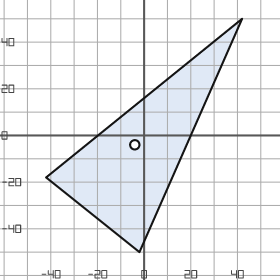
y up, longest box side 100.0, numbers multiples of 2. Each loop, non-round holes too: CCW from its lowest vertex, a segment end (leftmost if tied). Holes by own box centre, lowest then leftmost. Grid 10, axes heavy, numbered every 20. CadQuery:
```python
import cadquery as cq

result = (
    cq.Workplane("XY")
    .moveTo(-2.0, -50.0)
    .lineTo(42.0, 50.0)
    .lineTo(-42.0, -18.0)
    .close()
    .moveTo(-4.0, -4.0)
    .circle(2.0)
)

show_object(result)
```